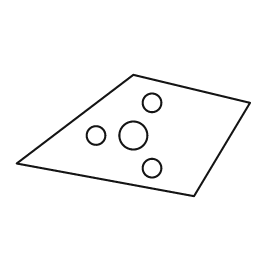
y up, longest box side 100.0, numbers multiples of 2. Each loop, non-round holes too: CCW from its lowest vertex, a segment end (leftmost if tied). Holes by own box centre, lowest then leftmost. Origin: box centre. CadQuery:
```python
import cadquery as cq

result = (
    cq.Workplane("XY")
    .moveTo(26.0, -26.0)
    .lineTo(50.0, 14.0)
    .lineTo(0.0, 26.0)
    .lineTo(-50.0, -12.0)
    .close()
    .moveTo(8.0, -14.0)
    .circle(4.0)
    .moveTo(-16.0, 0.0)
    .circle(4.0)
    .moveTo(0.0, 0.0)
    .circle(6.0)
    .moveTo(8.0, 14.0)
    .circle(4.0)
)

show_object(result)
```